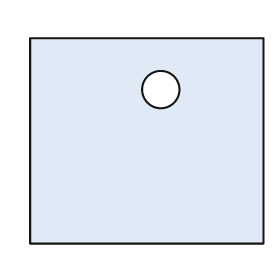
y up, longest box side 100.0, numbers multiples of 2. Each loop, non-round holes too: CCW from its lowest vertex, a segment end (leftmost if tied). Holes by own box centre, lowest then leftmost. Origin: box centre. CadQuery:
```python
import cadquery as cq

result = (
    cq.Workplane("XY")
    .moveTo(-50.0, -44.0)
    .lineTo(50.0, -44.0)
    .lineTo(50.0, 44.0)
    .lineTo(-50.0, 44.0)
    .close()
    .moveTo(6.0, 22.0)
    .circle(8.0)
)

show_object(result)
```